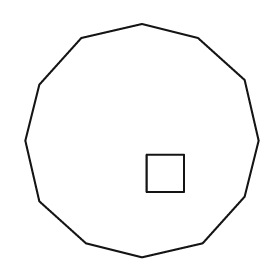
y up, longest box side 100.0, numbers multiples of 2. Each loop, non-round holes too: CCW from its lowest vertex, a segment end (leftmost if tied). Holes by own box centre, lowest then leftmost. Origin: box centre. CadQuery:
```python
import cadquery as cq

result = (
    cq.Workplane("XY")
    .moveTo(0.0, -50.0)
    .lineTo(26.0, -44.0)
    .lineTo(44.0, -24.0)
    .lineTo(50.0, 0.0)
    .lineTo(44.0, 26.0)
    .lineTo(24.0, 44.0)
    .lineTo(0.0, 50.0)
    .lineTo(-26.0, 44.0)
    .lineTo(-44.0, 24.0)
    .lineTo(-50.0, 0.0)
    .lineTo(-44.0, -26.0)
    .lineTo(-24.0, -44.0)
    .close()
    .moveTo(2.0, -22.0)
    .lineTo(18.0, -22.0)
    .lineTo(18.0, -6.0)
    .lineTo(2.0, -6.0)
    .close()
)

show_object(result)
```